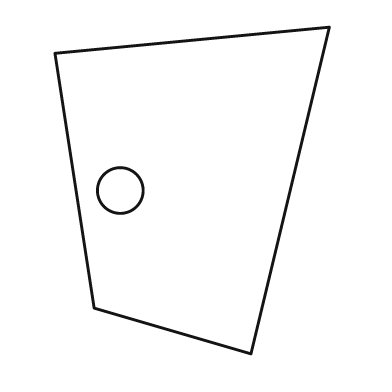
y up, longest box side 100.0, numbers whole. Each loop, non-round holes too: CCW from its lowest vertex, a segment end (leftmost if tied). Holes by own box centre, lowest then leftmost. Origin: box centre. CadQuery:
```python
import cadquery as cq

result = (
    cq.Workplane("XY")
    .moveTo(18.0, -50.0)
    .lineTo(42.0, 50.0)
    .lineTo(-42.0, 42.0)
    .lineTo(-30.0, -36.0)
    .close()
    .moveTo(-22.0, 0.0)
    .circle(7.0)
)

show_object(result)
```